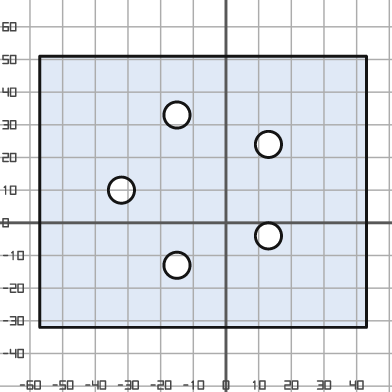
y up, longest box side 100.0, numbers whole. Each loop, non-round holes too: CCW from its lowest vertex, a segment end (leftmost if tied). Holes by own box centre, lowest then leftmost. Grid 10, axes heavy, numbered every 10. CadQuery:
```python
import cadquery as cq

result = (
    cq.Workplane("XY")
    .moveTo(-57.0, -32.0)
    .lineTo(43.0, -32.0)
    .lineTo(43.0, 51.0)
    .lineTo(-57.0, 51.0)
    .close()
    .moveTo(-15.0, -13.0)
    .circle(4.0)
    .moveTo(13.0, -4.0)
    .circle(4.0)
    .moveTo(-32.0, 10.0)
    .circle(4.0)
    .moveTo(13.0, 24.0)
    .circle(4.0)
    .moveTo(-15.0, 33.0)
    .circle(4.0)
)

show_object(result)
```